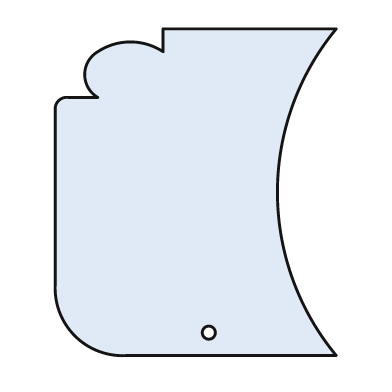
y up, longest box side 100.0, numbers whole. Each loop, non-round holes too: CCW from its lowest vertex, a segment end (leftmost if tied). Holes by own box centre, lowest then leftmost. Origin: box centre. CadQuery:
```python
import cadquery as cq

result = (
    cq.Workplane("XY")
    .moveTo(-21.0, -50.0)
    .lineTo(43.0, -50.0)
    .threePointArc((25.0, 0.0), (43.0, 50.0))
    .lineTo(-10.0, 50.0)
    .lineTo(-10.0, 43.0)
    .threePointArc((-20.0, 46.0), (-30.0, 43.0))
    .threePointArc((-34.0, 36.0), (-30.0, 29.0))
    .lineTo(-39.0, 29.0)
    .threePointArc((-42.0, 28.0), (-43.0, 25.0))
    .lineTo(-43.0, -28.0)
    .threePointArc((-37.0, -44.0), (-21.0, -50.0))
    .close()
    .moveTo(4.0, -43.0)
    .circle(2.0)
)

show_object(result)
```